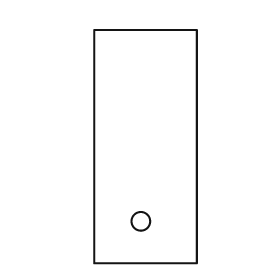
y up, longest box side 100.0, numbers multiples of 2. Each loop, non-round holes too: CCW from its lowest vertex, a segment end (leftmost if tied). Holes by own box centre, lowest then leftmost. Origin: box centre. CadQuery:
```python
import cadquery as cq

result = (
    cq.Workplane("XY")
    .moveTo(-22.0, -50.0)
    .lineTo(22.0, -50.0)
    .lineTo(22.0, 50.0)
    .lineTo(-22.0, 50.0)
    .close()
    .moveTo(-2.0, -32.0)
    .circle(4.0)
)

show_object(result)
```